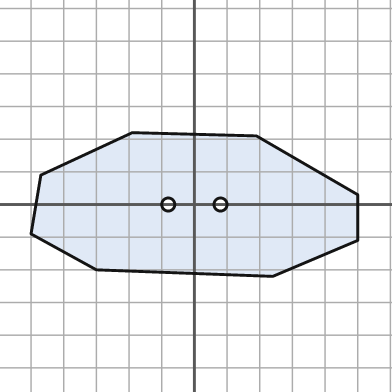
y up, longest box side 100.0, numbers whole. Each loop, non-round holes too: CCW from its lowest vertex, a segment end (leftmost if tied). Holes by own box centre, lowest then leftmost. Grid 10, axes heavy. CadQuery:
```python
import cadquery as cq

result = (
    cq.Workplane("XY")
    .moveTo(24.0, -22.0)
    .lineTo(50.0, -11.0)
    .lineTo(50.0, 3.0)
    .lineTo(19.0, 21.0)
    .lineTo(-19.0, 22.0)
    .lineTo(-47.0, 9.0)
    .lineTo(-50.0, -9.0)
    .lineTo(-30.0, -20.0)
    .close()
    .moveTo(-8.0, 0.0)
    .circle(2.0)
    .moveTo(8.0, 0.0)
    .circle(2.0)
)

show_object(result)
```